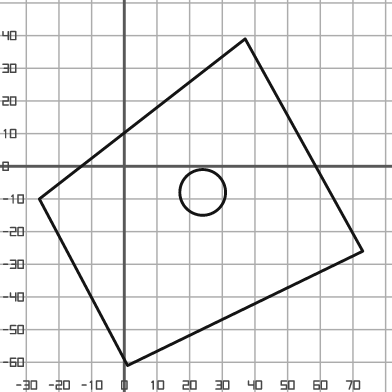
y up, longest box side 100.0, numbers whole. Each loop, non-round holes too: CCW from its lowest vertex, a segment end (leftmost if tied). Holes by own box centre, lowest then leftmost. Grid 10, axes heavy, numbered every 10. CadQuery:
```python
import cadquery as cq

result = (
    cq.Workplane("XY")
    .moveTo(1.0, -61.0)
    .lineTo(73.0, -26.0)
    .lineTo(37.0, 39.0)
    .lineTo(-26.0, -10.0)
    .close()
    .moveTo(24.0, -8.0)
    .circle(7.0)
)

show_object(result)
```